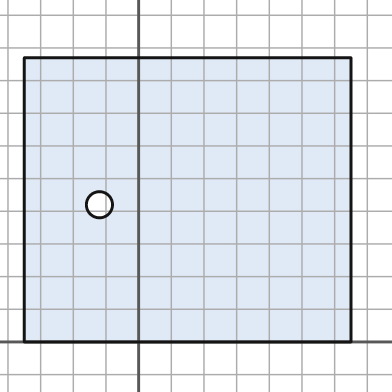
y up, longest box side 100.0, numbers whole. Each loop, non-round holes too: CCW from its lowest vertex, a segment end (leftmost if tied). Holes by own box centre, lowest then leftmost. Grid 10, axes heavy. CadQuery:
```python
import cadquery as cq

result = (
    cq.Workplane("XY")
    .moveTo(-35.0, 0.0)
    .lineTo(65.0, 0.0)
    .lineTo(65.0, 87.0)
    .lineTo(-35.0, 87.0)
    .close()
    .moveTo(-12.0, 42.0)
    .circle(4.0)
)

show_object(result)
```